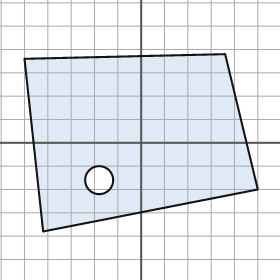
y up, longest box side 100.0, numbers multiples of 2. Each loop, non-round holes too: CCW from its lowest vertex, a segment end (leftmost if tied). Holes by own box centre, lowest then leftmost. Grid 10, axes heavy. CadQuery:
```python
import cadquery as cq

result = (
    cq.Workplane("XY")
    .moveTo(-42.0, -38.0)
    .lineTo(50.0, -20.0)
    .lineTo(36.0, 38.0)
    .lineTo(-50.0, 36.0)
    .close()
    .moveTo(-18.0, -16.0)
    .circle(6.0)
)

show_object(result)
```